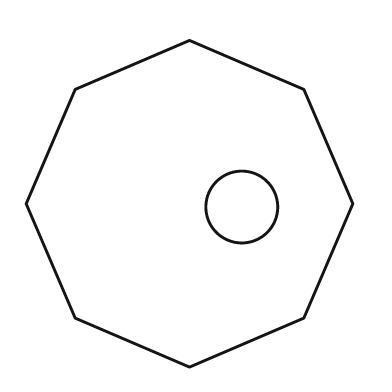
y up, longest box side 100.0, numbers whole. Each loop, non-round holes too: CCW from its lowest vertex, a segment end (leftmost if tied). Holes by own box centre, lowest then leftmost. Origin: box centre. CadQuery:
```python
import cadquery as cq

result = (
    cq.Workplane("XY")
    .moveTo(0.0, -50.0)
    .lineTo(35.0, -35.0)
    .lineTo(50.0, 0.0)
    .lineTo(35.0, 35.0)
    .lineTo(0.0, 50.0)
    .lineTo(-35.0, 35.0)
    .lineTo(-50.0, 0.0)
    .lineTo(-35.0, -35.0)
    .close()
    .moveTo(16.0, -1.0)
    .circle(11.0)
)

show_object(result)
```